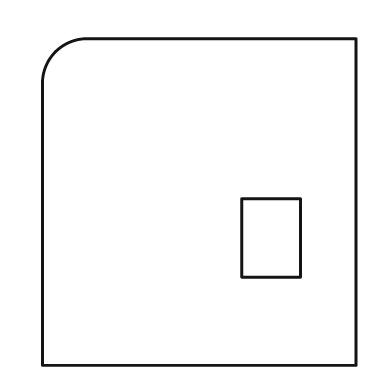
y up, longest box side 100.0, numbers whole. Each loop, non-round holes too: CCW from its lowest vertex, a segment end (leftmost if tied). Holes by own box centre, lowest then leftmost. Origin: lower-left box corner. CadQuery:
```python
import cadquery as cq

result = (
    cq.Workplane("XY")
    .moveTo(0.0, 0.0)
    .lineTo(96.0, 0.0)
    .lineTo(96.0, 100.0)
    .lineTo(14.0, 100.0)
    .threePointArc((4.0, 96.0), (0.0, 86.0))
    .close()
    .moveTo(61.0, 27.0)
    .lineTo(79.0, 27.0)
    .lineTo(79.0, 51.0)
    .lineTo(61.0, 51.0)
    .close()
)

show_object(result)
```